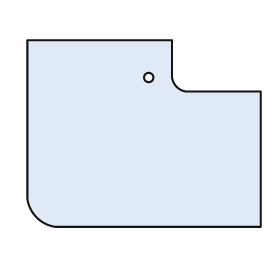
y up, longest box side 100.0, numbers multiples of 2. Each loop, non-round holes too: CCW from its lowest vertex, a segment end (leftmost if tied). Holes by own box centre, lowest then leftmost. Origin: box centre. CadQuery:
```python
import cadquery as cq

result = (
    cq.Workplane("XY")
    .moveTo(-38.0, -40.0)
    .lineTo(50.0, -40.0)
    .lineTo(50.0, 18.0)
    .lineTo(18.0, 18.0)
    .threePointArc((14.0, 20.0), (12.0, 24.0))
    .lineTo(12.0, 40.0)
    .lineTo(-50.0, 40.0)
    .lineTo(-50.0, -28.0)
    .threePointArc((-46.0, -36.0), (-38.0, -40.0))
    .close()
    .moveTo(2.0, 24.0)
    .circle(2.0)
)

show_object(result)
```